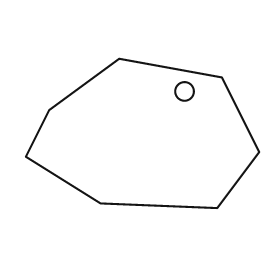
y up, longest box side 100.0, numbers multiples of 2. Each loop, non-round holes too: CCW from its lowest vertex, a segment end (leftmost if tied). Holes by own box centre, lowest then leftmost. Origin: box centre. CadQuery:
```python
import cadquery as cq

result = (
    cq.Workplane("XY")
    .moveTo(32.0, -32.0)
    .lineTo(50.0, -8.0)
    .lineTo(34.0, 24.0)
    .lineTo(-10.0, 32.0)
    .lineTo(-40.0, 10.0)
    .lineTo(-50.0, -10.0)
    .lineTo(-18.0, -30.0)
    .close()
    .moveTo(18.0, 18.0)
    .circle(4.0)
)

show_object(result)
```